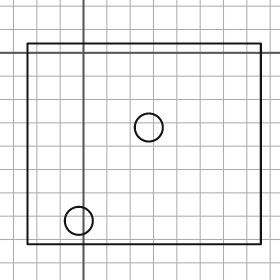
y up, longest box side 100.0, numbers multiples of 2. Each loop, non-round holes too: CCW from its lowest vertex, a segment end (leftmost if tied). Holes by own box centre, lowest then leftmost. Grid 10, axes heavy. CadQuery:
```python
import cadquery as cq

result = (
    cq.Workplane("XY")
    .moveTo(-24.0, -82.0)
    .lineTo(76.0, -82.0)
    .lineTo(76.0, 4.0)
    .lineTo(-24.0, 4.0)
    .close()
    .moveTo(-2.0, -72.0)
    .circle(6.0)
    .moveTo(28.0, -32.0)
    .circle(6.0)
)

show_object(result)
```